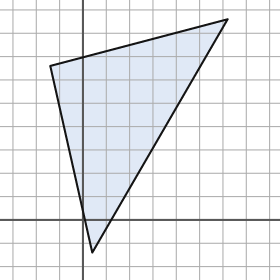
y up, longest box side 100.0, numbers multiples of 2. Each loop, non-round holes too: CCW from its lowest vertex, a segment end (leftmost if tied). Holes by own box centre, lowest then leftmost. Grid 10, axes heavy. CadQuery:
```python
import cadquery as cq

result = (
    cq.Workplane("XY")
    .moveTo(4.0, -14.0)
    .lineTo(62.0, 86.0)
    .lineTo(-14.0, 66.0)
    .close()
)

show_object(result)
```